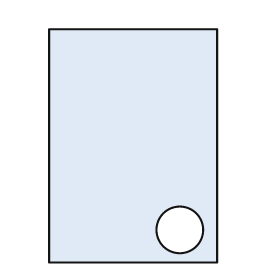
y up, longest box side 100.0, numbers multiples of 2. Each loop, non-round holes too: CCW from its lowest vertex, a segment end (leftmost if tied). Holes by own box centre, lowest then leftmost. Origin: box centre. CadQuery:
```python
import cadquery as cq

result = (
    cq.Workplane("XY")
    .moveTo(-36.0, -50.0)
    .lineTo(36.0, -50.0)
    .lineTo(36.0, 50.0)
    .lineTo(-36.0, 50.0)
    .close()
    .moveTo(20.0, -36.0)
    .circle(10.0)
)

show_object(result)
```